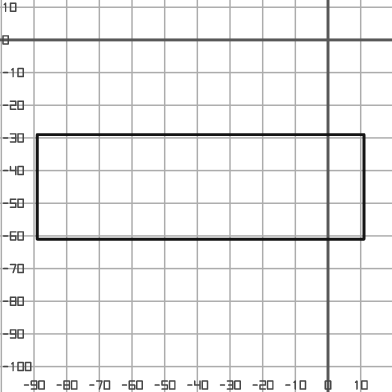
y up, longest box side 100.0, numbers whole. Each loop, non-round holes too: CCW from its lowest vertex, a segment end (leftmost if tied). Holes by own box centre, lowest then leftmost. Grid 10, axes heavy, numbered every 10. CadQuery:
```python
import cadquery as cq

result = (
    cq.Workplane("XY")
    .moveTo(-89.0, -61.0)
    .lineTo(11.0, -61.0)
    .lineTo(11.0, -29.0)
    .lineTo(-89.0, -29.0)
    .close()
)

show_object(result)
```